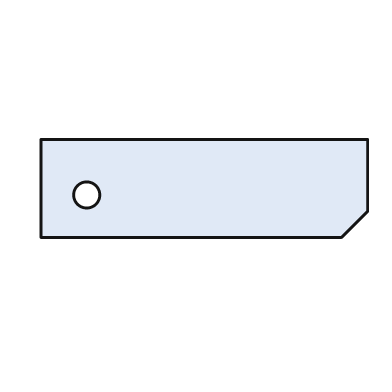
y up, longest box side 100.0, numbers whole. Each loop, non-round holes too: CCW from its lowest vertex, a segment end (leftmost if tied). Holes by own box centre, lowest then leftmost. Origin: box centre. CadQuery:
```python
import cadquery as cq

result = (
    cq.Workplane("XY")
    .moveTo(-50.0, -15.0)
    .lineTo(42.0, -15.0)
    .lineTo(50.0, -7.0)
    .lineTo(50.0, 15.0)
    .lineTo(-50.0, 15.0)
    .close()
    .moveTo(-36.0, -2.0)
    .circle(4.0)
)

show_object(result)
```